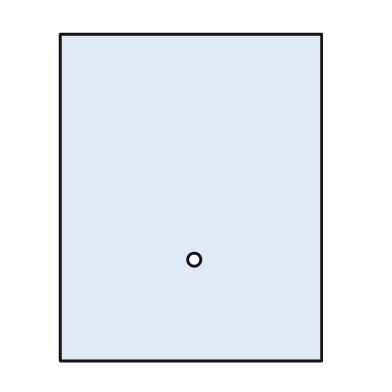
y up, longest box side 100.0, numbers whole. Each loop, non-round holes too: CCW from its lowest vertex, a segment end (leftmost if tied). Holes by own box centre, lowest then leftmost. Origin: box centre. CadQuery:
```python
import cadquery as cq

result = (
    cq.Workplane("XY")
    .moveTo(-40.0, -50.0)
    .lineTo(40.0, -50.0)
    .lineTo(40.0, 50.0)
    .lineTo(-40.0, 50.0)
    .close()
    .moveTo(1.0, -19.0)
    .circle(2.0)
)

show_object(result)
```